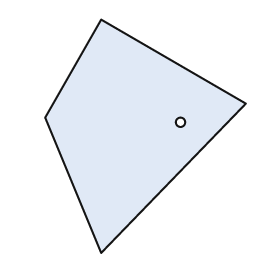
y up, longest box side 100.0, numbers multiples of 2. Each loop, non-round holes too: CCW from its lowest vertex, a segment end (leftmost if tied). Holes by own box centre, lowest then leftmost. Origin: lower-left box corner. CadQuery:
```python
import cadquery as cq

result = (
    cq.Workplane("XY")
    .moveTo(24.0, 0.0)
    .lineTo(86.0, 64.0)
    .lineTo(24.0, 100.0)
    .lineTo(0.0, 58.0)
    .close()
    .moveTo(58.0, 56.0)
    .circle(2.0)
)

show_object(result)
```